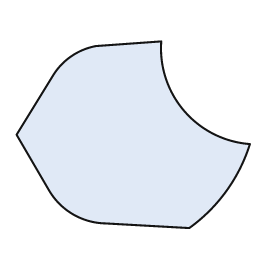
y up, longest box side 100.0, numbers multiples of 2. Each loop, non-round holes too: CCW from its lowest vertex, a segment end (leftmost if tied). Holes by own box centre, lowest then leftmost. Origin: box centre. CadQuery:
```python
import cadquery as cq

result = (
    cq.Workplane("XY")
    .moveTo(24.0, -40.0)
    .threePointArc((40.0, -24.0), (50.0, -4.0))
    .threePointArc((22.0, 10.0), (12.0, 40.0))
    .lineTo(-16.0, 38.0)
    .threePointArc((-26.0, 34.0), (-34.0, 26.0))
    .lineTo(-50.0, 0.0)
    .lineTo(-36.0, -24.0)
    .threePointArc((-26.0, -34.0), (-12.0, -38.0))
    .close()
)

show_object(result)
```